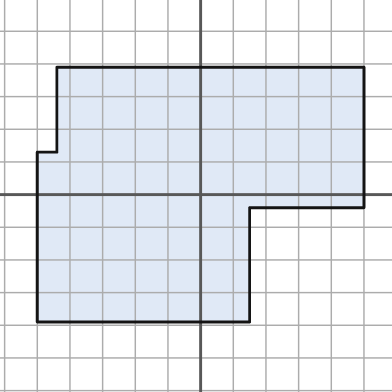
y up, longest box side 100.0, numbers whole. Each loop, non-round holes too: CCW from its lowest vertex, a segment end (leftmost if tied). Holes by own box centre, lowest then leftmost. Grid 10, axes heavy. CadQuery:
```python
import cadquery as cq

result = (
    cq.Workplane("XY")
    .moveTo(-50.0, -39.0)
    .lineTo(15.0, -39.0)
    .lineTo(15.0, -4.0)
    .lineTo(50.0, -4.0)
    .lineTo(50.0, 39.0)
    .lineTo(-44.0, 39.0)
    .lineTo(-44.0, 13.0)
    .lineTo(-50.0, 13.0)
    .close()
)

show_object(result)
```